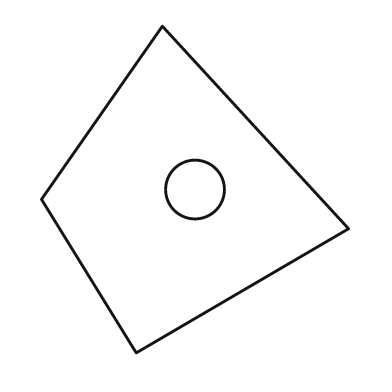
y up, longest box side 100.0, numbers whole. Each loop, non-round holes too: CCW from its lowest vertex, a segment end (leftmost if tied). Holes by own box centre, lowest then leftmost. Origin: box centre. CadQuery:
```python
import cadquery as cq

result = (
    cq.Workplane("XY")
    .moveTo(-18.0, -50.0)
    .lineTo(47.0, -12.0)
    .lineTo(-10.0, 50.0)
    .lineTo(-47.0, -3.0)
    .close()
    .moveTo(0.0, 0.0)
    .circle(9.0)
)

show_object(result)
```